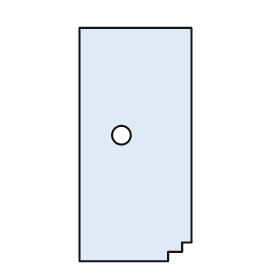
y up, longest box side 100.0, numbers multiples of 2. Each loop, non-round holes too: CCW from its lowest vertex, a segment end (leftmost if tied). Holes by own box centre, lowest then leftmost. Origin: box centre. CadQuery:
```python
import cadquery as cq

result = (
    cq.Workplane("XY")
    .moveTo(-24.0, -50.0)
    .lineTo(14.0, -50.0)
    .lineTo(14.0, -46.0)
    .lineTo(20.0, -46.0)
    .lineTo(20.0, -42.0)
    .lineTo(24.0, -42.0)
    .lineTo(24.0, 50.0)
    .lineTo(-24.0, 50.0)
    .close()
    .moveTo(-6.0, 4.0)
    .circle(4.0)
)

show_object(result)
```